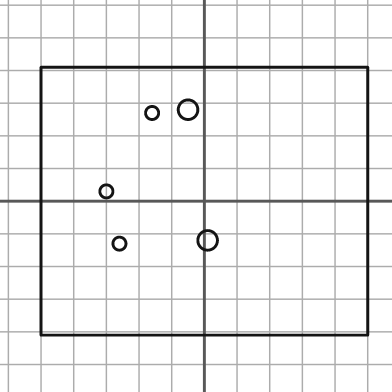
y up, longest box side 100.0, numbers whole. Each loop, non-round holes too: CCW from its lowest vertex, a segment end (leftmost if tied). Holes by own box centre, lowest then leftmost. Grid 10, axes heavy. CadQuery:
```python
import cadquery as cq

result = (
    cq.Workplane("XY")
    .moveTo(-50.0, -41.0)
    .lineTo(50.0, -41.0)
    .lineTo(50.0, 41.0)
    .lineTo(-50.0, 41.0)
    .close()
    .moveTo(-26.0, -13.0)
    .circle(2.0)
    .moveTo(1.0, -12.0)
    .circle(3.0)
    .moveTo(-30.0, 3.0)
    .circle(2.0)
    .moveTo(-16.0, 27.0)
    .circle(2.0)
    .moveTo(-5.0, 28.0)
    .circle(3.0)
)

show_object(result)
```